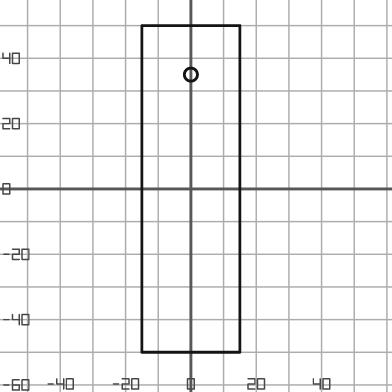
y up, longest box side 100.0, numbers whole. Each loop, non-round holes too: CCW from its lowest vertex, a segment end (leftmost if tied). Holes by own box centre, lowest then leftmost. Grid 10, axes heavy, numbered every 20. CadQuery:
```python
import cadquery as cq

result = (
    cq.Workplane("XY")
    .moveTo(-15.0, -50.0)
    .lineTo(15.0, -50.0)
    .lineTo(15.0, 50.0)
    .lineTo(-15.0, 50.0)
    .close()
    .moveTo(0.0, 35.0)
    .circle(2.0)
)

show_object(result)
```